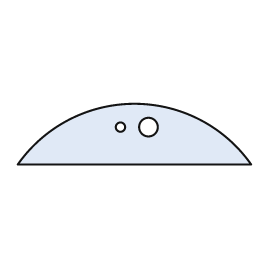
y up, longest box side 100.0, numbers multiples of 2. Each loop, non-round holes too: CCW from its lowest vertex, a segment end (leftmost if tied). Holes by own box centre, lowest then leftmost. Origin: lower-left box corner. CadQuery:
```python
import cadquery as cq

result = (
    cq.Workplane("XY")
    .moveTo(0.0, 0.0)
    .lineTo(100.0, 0.0)
    .threePointArc((50.0, 26.0), (0.0, 0.0))
    .close()
    .moveTo(44.0, 16.0)
    .circle(2.0)
    .moveTo(56.0, 16.0)
    .circle(4.0)
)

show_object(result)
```